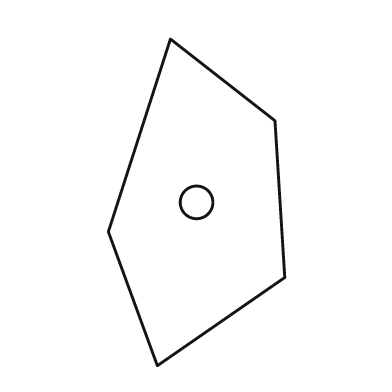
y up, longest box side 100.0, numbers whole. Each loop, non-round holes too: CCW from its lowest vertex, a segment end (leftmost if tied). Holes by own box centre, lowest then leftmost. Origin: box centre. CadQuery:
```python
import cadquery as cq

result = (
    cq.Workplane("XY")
    .moveTo(-12.0, -50.0)
    .lineTo(27.0, -23.0)
    .lineTo(24.0, 25.0)
    .lineTo(-8.0, 50.0)
    .lineTo(-27.0, -9.0)
    .close()
    .moveTo(0.0, 0.0)
    .circle(5.0)
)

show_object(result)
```